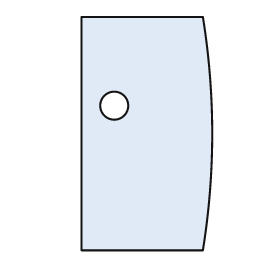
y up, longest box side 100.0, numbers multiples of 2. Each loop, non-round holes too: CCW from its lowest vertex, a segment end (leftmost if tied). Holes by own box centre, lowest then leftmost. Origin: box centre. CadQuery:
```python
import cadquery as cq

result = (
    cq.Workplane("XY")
    .moveTo(-28.0, -50.0)
    .lineTo(24.0, -50.0)
    .threePointArc((28.0, 0.0), (24.0, 50.0))
    .lineTo(-28.0, 50.0)
    .close()
    .moveTo(-14.0, 12.0)
    .circle(6.0)
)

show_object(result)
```